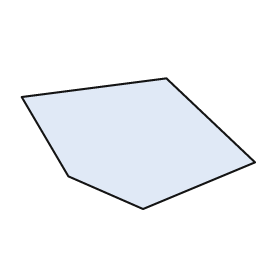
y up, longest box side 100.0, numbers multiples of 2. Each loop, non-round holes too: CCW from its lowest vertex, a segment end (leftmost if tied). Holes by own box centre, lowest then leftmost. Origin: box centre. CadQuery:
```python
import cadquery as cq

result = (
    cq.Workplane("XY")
    .moveTo(2.0, -28.0)
    .lineTo(50.0, -8.0)
    .lineTo(12.0, 28.0)
    .lineTo(-50.0, 20.0)
    .lineTo(-30.0, -14.0)
    .close()
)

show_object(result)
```